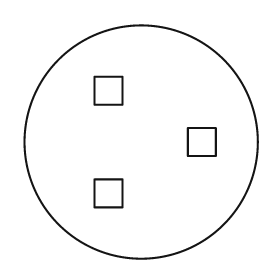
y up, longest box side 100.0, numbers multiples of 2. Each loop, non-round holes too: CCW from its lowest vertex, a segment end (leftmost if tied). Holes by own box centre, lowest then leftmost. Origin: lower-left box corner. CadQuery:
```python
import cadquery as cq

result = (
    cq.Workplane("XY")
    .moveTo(50.0, 50.0)
    .circle(50.0)
    .moveTo(30.0, 22.0)
    .lineTo(42.0, 22.0)
    .lineTo(42.0, 34.0)
    .lineTo(30.0, 34.0)
    .close()
    .moveTo(70.0, 44.0)
    .lineTo(82.0, 44.0)
    .lineTo(82.0, 56.0)
    .lineTo(70.0, 56.0)
    .close()
    .moveTo(30.0, 66.0)
    .lineTo(42.0, 66.0)
    .lineTo(42.0, 78.0)
    .lineTo(30.0, 78.0)
    .close()
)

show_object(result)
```